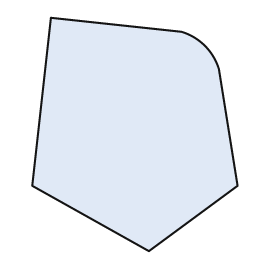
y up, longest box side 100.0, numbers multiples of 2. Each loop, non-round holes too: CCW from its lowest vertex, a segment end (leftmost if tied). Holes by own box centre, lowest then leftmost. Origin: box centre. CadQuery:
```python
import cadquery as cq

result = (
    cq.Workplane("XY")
    .moveTo(6.0, -50.0)
    .lineTo(44.0, -22.0)
    .lineTo(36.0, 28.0)
    .threePointArc((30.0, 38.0), (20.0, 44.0))
    .lineTo(-36.0, 50.0)
    .lineTo(-44.0, -22.0)
    .close()
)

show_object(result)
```